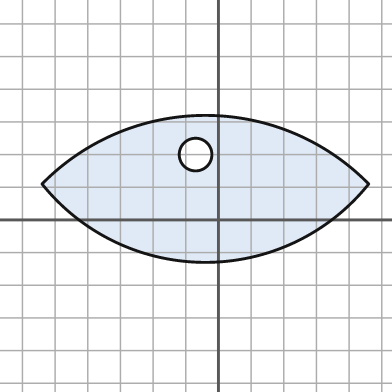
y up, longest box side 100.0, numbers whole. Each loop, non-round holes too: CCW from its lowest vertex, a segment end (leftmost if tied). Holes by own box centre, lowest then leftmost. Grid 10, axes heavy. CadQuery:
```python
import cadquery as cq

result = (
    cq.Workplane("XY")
    .moveTo(-54.0, 11.0)
    .threePointArc((-4.0, -13.0), (46.0, 11.0))
    .threePointArc((-4.0, 32.0), (-54.0, 11.0))
    .close()
    .moveTo(-7.0, 20.0)
    .circle(5.0)
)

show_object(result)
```